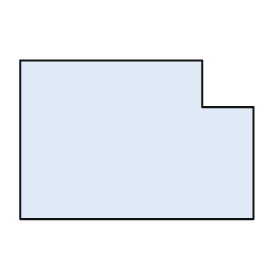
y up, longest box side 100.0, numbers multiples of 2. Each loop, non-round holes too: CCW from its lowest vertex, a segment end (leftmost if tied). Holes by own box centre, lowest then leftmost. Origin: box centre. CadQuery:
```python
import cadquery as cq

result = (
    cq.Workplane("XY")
    .moveTo(-50.0, -34.0)
    .lineTo(50.0, -34.0)
    .lineTo(50.0, 14.0)
    .lineTo(28.0, 14.0)
    .lineTo(28.0, 34.0)
    .lineTo(-50.0, 34.0)
    .close()
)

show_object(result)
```